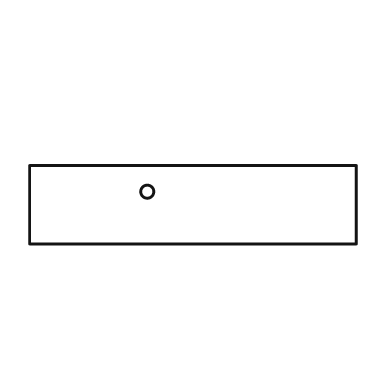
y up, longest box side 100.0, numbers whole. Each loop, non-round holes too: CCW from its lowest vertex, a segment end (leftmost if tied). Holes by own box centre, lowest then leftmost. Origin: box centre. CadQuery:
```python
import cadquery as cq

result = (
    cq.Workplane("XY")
    .moveTo(-50.0, -12.0)
    .lineTo(50.0, -12.0)
    .lineTo(50.0, 12.0)
    .lineTo(-50.0, 12.0)
    .close()
    .moveTo(-14.0, 4.0)
    .circle(2.0)
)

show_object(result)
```